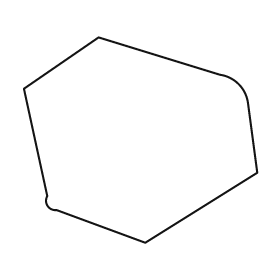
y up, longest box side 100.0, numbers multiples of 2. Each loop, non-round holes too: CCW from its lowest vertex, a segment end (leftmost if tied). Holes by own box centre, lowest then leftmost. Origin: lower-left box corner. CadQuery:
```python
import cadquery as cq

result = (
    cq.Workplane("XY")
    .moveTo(52.0, 0.0)
    .lineTo(100.0, 30.0)
    .lineTo(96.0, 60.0)
    .threePointArc((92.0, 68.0), (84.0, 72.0))
    .lineTo(32.0, 88.0)
    .lineTo(0.0, 66.0)
    .lineTo(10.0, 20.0)
    .threePointArc((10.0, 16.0), (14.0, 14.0))
    .close()
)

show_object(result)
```